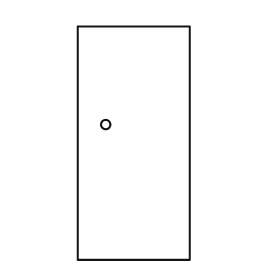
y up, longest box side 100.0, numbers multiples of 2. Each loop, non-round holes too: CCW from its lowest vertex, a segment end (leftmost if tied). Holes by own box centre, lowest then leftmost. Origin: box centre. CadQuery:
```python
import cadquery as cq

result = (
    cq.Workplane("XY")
    .moveTo(-24.0, -50.0)
    .lineTo(24.0, -50.0)
    .lineTo(24.0, 50.0)
    .lineTo(-24.0, 50.0)
    .close()
    .moveTo(-12.0, 8.0)
    .circle(2.0)
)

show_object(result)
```